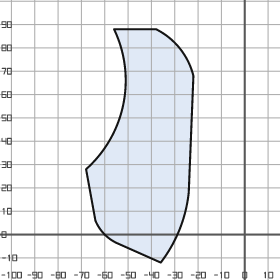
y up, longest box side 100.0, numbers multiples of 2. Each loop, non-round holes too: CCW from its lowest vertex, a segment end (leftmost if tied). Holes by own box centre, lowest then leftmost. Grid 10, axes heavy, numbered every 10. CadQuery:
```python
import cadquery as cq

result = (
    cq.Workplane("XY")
    .moveTo(-36.0, -12.0)
    .threePointArc((-28.0, 2.0), (-24.0, 18.0))
    .lineTo(-22.0, 68.0)
    .threePointArc((-28.0, 80.0), (-38.0, 88.0))
    .lineTo(-56.0, 88.0)
    .threePointArc((-52.0, 56.0), (-68.0, 28.0))
    .lineTo(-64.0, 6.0)
    .threePointArc((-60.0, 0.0), (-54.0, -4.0))
    .close()
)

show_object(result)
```